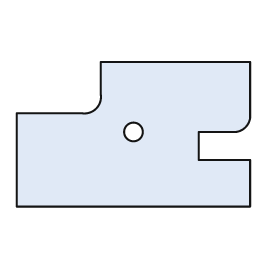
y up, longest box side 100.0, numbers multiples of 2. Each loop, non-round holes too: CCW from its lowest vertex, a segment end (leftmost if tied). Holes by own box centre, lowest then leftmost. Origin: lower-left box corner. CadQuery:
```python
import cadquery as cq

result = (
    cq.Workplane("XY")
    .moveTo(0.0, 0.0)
    .lineTo(100.0, 0.0)
    .lineTo(100.0, 20.0)
    .lineTo(78.0, 20.0)
    .lineTo(78.0, 32.0)
    .lineTo(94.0, 32.0)
    .threePointArc((98.0, 34.0), (100.0, 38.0))
    .lineTo(100.0, 62.0)
    .lineTo(36.0, 62.0)
    .lineTo(36.0, 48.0)
    .threePointArc((34.0, 42.0), (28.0, 40.0))
    .lineTo(0.0, 40.0)
    .close()
    .moveTo(50.0, 32.0)
    .circle(4.0)
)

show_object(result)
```